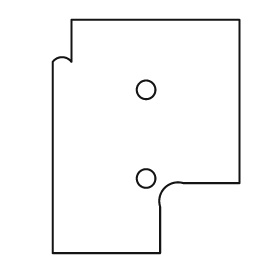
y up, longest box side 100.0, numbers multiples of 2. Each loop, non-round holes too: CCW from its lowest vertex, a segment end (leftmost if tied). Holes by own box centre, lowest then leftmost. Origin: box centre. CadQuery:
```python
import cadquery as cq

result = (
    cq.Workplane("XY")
    .moveTo(-40.0, -50.0)
    .lineTo(6.0, -50.0)
    .lineTo(6.0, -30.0)
    .threePointArc((8.0, -22.0), (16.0, -20.0))
    .lineTo(40.0, -20.0)
    .lineTo(40.0, 50.0)
    .lineTo(-32.0, 50.0)
    .lineTo(-32.0, 32.0)
    .threePointArc((-36.0, 34.0), (-40.0, 32.0))
    .close()
    .moveTo(0.0, -18.0)
    .circle(4.0)
    .moveTo(0.0, 20.0)
    .circle(4.0)
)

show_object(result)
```